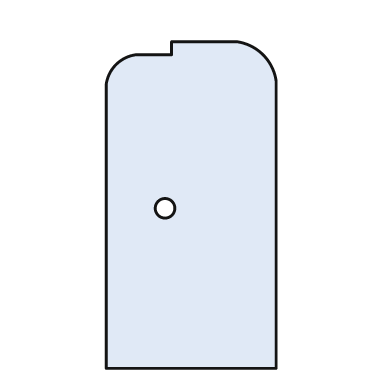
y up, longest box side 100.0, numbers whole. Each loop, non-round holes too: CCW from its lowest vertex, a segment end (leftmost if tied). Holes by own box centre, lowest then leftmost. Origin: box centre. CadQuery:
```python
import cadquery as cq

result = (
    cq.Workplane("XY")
    .moveTo(-26.0, -50.0)
    .lineTo(26.0, -50.0)
    .lineTo(26.0, 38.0)
    .threePointArc((22.0, 46.0), (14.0, 50.0))
    .lineTo(-6.0, 50.0)
    .lineTo(-6.0, 46.0)
    .lineTo(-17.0, 46.0)
    .threePointArc((-23.0, 43.0), (-26.0, 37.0))
    .close()
    .moveTo(-8.0, -1.0)
    .circle(3.0)
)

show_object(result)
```